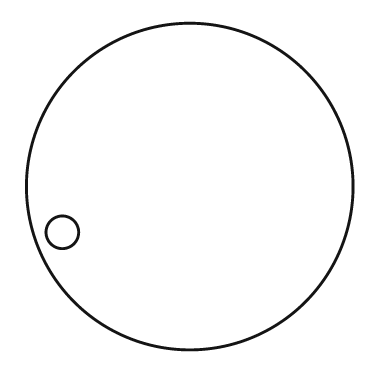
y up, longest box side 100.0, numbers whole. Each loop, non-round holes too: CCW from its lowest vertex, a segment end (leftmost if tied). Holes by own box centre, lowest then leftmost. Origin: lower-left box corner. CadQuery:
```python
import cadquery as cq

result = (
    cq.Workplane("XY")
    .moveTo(50.0, 50.0)
    .circle(50.0)
    .moveTo(11.0, 36.0)
    .circle(5.0)
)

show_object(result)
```